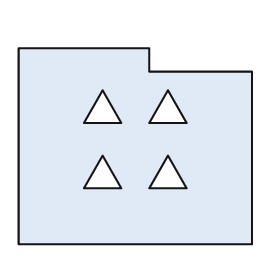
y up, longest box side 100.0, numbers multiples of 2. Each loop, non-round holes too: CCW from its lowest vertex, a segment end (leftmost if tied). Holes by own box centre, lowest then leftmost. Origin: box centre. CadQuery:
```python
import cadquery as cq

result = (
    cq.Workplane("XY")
    .moveTo(-50.0, -42.0)
    .lineTo(50.0, -42.0)
    .lineTo(50.0, 32.0)
    .lineTo(6.0, 32.0)
    .lineTo(6.0, 42.0)
    .lineTo(-50.0, 42.0)
    .close()
    .moveTo(-22.0, -18.0)
    .lineTo(-6.0, -18.0)
    .lineTo(-14.0, -4.0)
    .close()
    .moveTo(6.0, -18.0)
    .lineTo(22.0, -18.0)
    .lineTo(14.0, -4.0)
    .close()
    .moveTo(-22.0, 10.0)
    .lineTo(-6.0, 10.0)
    .lineTo(-14.0, 24.0)
    .close()
    .moveTo(6.0, 10.0)
    .lineTo(22.0, 10.0)
    .lineTo(14.0, 24.0)
    .close()
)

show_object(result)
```